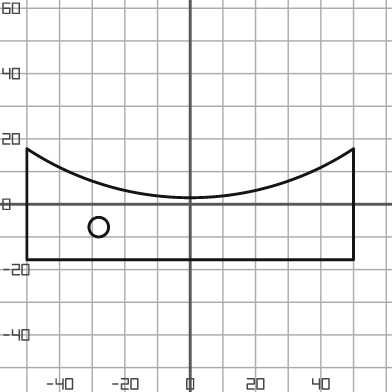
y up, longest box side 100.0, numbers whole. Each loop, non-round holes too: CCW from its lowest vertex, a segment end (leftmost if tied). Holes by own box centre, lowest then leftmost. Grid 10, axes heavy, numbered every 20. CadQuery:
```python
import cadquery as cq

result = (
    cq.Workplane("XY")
    .moveTo(-50.0, -17.0)
    .lineTo(50.0, -17.0)
    .lineTo(50.0, 17.0)
    .threePointArc((0.0, 2.0), (-50.0, 17.0))
    .close()
    .moveTo(-28.0, -7.0)
    .circle(3.0)
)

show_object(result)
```